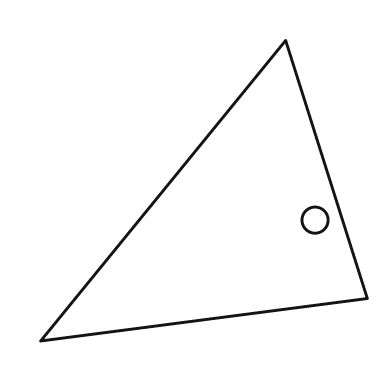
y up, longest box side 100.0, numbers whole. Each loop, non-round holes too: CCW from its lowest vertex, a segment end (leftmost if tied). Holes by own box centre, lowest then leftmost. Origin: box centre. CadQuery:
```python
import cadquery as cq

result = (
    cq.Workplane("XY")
    .moveTo(-50.0, -46.0)
    .lineTo(50.0, -33.0)
    .lineTo(25.0, 46.0)
    .close()
    .moveTo(34.0, -9.0)
    .circle(4.0)
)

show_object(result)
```